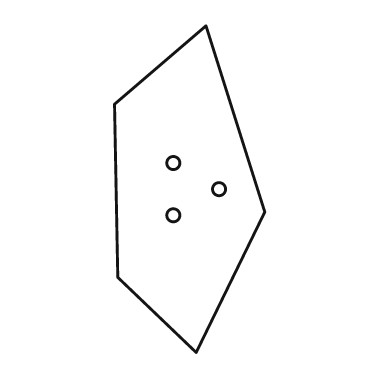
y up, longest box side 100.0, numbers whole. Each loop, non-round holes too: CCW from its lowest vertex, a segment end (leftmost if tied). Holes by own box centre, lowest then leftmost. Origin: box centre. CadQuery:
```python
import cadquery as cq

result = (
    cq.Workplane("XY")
    .moveTo(2.0, -50.0)
    .lineTo(23.0, -7.0)
    .lineTo(5.0, 50.0)
    .lineTo(-23.0, 26.0)
    .lineTo(-22.0, -27.0)
    .close()
    .moveTo(-5.0, -8.0)
    .circle(2.0)
    .moveTo(9.0, 0.0)
    .circle(2.0)
    .moveTo(-5.0, 8.0)
    .circle(2.0)
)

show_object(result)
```